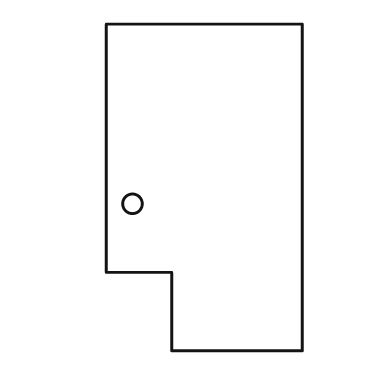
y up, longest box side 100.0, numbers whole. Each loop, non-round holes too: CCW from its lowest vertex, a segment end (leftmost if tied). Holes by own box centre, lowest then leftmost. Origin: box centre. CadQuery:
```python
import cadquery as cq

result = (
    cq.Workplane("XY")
    .moveTo(-10.0, -50.0)
    .lineTo(30.0, -50.0)
    .lineTo(30.0, 50.0)
    .lineTo(-30.0, 50.0)
    .lineTo(-30.0, -26.0)
    .lineTo(-10.0, -26.0)
    .close()
    .moveTo(-22.0, -5.0)
    .circle(3.0)
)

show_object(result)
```